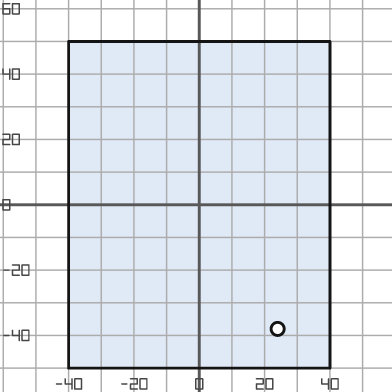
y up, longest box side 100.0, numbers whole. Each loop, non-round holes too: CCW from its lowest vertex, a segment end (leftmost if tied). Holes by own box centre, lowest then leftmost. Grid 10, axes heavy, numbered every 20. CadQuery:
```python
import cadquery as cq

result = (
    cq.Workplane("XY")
    .moveTo(-40.0, -50.0)
    .lineTo(40.0, -50.0)
    .lineTo(40.0, 50.0)
    .lineTo(-40.0, 50.0)
    .close()
    .moveTo(24.0, -38.0)
    .circle(2.0)
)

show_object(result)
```